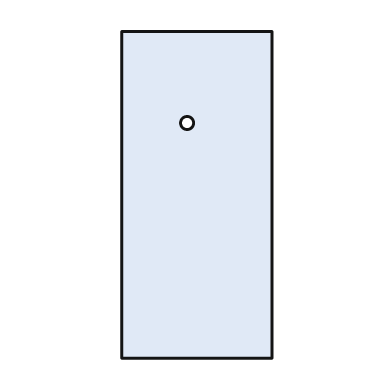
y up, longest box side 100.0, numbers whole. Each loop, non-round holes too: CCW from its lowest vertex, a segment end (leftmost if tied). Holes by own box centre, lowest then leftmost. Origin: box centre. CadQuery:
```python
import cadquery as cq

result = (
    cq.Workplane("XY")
    .moveTo(-23.0, -50.0)
    .lineTo(23.0, -50.0)
    .lineTo(23.0, 50.0)
    .lineTo(-23.0, 50.0)
    .close()
    .moveTo(-3.0, 22.0)
    .circle(2.0)
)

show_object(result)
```